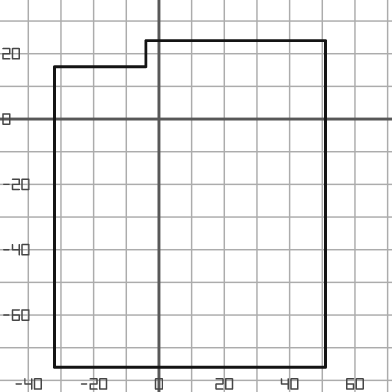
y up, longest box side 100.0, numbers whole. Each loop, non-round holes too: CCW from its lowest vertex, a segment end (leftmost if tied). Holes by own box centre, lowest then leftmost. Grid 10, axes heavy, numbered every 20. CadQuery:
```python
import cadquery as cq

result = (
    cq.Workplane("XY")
    .moveTo(-32.0, -76.0)
    .lineTo(51.0, -76.0)
    .lineTo(51.0, 24.0)
    .lineTo(-4.0, 24.0)
    .lineTo(-4.0, 16.0)
    .lineTo(-32.0, 16.0)
    .close()
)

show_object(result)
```